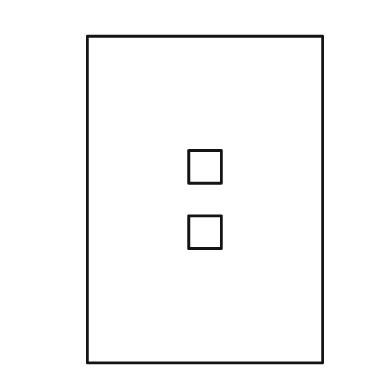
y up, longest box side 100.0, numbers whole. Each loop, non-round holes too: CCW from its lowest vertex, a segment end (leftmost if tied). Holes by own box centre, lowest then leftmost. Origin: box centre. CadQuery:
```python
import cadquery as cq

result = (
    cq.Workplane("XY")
    .moveTo(-36.0, -50.0)
    .lineTo(36.0, -50.0)
    .lineTo(36.0, 50.0)
    .lineTo(-36.0, 50.0)
    .close()
    .moveTo(-5.0, -15.0)
    .lineTo(5.0, -15.0)
    .lineTo(5.0, -5.0)
    .lineTo(-5.0, -5.0)
    .close()
    .moveTo(-5.0, 5.0)
    .lineTo(5.0, 5.0)
    .lineTo(5.0, 15.0)
    .lineTo(-5.0, 15.0)
    .close()
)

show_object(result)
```